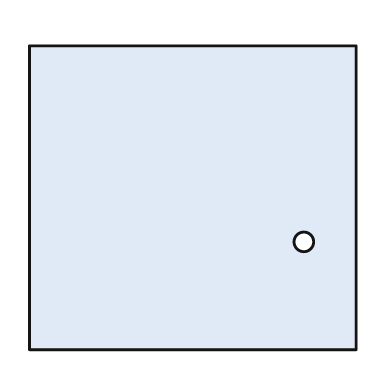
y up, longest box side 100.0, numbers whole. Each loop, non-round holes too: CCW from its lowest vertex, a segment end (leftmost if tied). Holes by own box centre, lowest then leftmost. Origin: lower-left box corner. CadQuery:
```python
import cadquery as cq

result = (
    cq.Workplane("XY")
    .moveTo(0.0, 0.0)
    .lineTo(100.0, 0.0)
    .lineTo(100.0, 93.0)
    .lineTo(0.0, 93.0)
    .close()
    .moveTo(84.0, 33.0)
    .circle(3.0)
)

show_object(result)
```